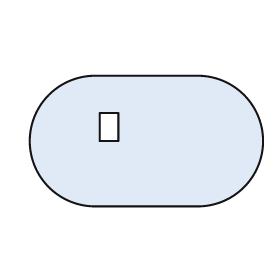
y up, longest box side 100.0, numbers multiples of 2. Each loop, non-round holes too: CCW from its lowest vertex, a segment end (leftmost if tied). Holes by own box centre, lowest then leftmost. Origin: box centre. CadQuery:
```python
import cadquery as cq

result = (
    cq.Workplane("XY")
    .moveTo(-22.0, -28.0)
    .lineTo(22.0, -28.0)
    .threePointArc((50.0, 0.0), (22.0, 28.0))
    .lineTo(-22.0, 28.0)
    .threePointArc((-50.0, 0.0), (-22.0, -28.0))
    .close()
    .moveTo(-20.0, 0.0)
    .lineTo(-12.0, 0.0)
    .lineTo(-12.0, 12.0)
    .lineTo(-20.0, 12.0)
    .close()
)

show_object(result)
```